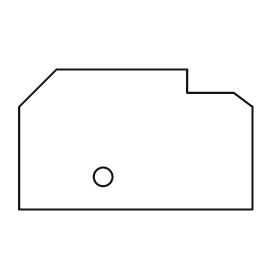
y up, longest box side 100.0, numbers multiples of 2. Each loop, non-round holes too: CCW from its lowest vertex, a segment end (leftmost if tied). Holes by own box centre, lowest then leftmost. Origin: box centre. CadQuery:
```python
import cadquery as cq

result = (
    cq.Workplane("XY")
    .moveTo(-50.0, -30.0)
    .lineTo(50.0, -30.0)
    .lineTo(50.0, 14.0)
    .lineTo(42.0, 20.0)
    .lineTo(22.0, 20.0)
    .lineTo(22.0, 30.0)
    .lineTo(-34.0, 30.0)
    .lineTo(-50.0, 14.0)
    .close()
    .moveTo(-14.0, -16.0)
    .circle(4.0)
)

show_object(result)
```